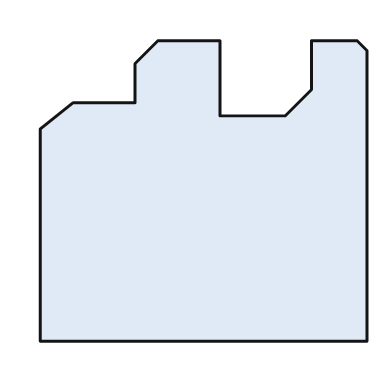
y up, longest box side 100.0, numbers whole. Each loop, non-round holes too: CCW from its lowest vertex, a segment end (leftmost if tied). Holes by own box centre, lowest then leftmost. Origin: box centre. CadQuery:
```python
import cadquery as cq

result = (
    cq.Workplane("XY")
    .moveTo(-50.0, -46.0)
    .lineTo(50.0, -46.0)
    .lineTo(50.0, 43.0)
    .lineTo(47.0, 46.0)
    .lineTo(33.0, 46.0)
    .lineTo(33.0, 31.0)
    .lineTo(25.0, 23.0)
    .lineTo(5.0, 23.0)
    .lineTo(5.0, 46.0)
    .lineTo(-14.0, 46.0)
    .lineTo(-21.0, 39.0)
    .lineTo(-21.0, 27.0)
    .lineTo(-40.0, 27.0)
    .lineTo(-50.0, 19.0)
    .close()
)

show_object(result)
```